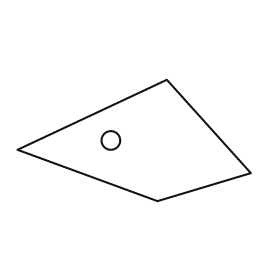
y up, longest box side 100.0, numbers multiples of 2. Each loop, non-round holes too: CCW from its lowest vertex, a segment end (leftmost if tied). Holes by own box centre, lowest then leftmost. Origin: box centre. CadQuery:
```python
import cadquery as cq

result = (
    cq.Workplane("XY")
    .moveTo(10.0, -26.0)
    .lineTo(50.0, -14.0)
    .lineTo(14.0, 26.0)
    .lineTo(-50.0, -4.0)
    .close()
    .moveTo(-10.0, 0.0)
    .circle(4.0)
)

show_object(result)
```